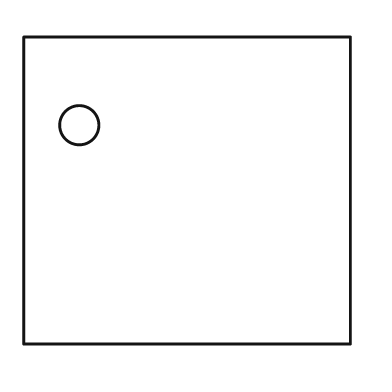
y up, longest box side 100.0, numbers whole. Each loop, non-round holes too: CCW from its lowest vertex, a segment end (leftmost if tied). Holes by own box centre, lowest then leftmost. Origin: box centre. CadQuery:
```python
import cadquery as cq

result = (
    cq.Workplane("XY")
    .moveTo(-50.0, -47.0)
    .lineTo(50.0, -47.0)
    .lineTo(50.0, 47.0)
    .lineTo(-50.0, 47.0)
    .close()
    .moveTo(-33.0, 20.0)
    .circle(6.0)
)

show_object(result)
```